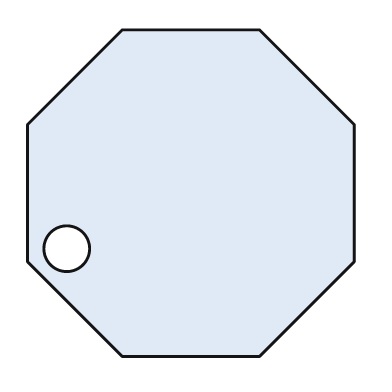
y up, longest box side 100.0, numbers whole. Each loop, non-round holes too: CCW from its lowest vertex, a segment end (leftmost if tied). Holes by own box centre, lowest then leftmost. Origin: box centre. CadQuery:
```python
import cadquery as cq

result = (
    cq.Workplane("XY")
    .moveTo(-21.0, -50.0)
    .lineTo(21.0, -50.0)
    .lineTo(50.0, -21.0)
    .lineTo(50.0, 21.0)
    .lineTo(21.0, 50.0)
    .lineTo(-21.0, 50.0)
    .lineTo(-50.0, 21.0)
    .lineTo(-50.0, -21.0)
    .close()
    .moveTo(-38.0, -17.0)
    .circle(7.0)
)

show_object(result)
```